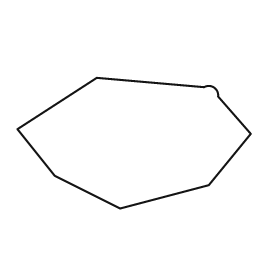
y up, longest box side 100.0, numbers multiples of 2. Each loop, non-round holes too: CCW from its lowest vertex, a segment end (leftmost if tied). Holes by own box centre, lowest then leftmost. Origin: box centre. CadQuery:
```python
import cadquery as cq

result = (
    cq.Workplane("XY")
    .moveTo(-6.0, -28.0)
    .lineTo(32.0, -18.0)
    .lineTo(50.0, 4.0)
    .lineTo(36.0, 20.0)
    .threePointArc((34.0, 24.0), (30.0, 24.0))
    .lineTo(-16.0, 28.0)
    .lineTo(-50.0, 6.0)
    .lineTo(-34.0, -14.0)
    .close()
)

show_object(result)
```